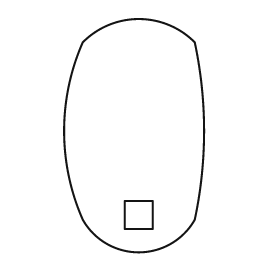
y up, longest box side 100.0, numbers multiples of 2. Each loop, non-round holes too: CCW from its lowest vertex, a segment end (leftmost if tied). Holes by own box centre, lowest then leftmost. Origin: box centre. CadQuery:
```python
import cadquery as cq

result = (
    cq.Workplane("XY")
    .moveTo(-22.0, -36.0)
    .threePointArc((2.0, -50.0), (26.0, -36.0))
    .threePointArc((30.0, 2.0), (26.0, 40.0))
    .threePointArc((2.0, 50.0), (-22.0, 40.0))
    .threePointArc((-30.0, 2.0), (-22.0, -36.0))
    .close()
    .moveTo(-4.0, -40.0)
    .lineTo(8.0, -40.0)
    .lineTo(8.0, -28.0)
    .lineTo(-4.0, -28.0)
    .close()
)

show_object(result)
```